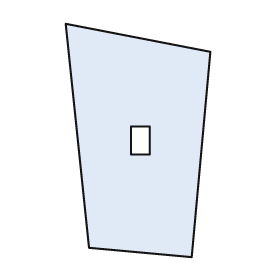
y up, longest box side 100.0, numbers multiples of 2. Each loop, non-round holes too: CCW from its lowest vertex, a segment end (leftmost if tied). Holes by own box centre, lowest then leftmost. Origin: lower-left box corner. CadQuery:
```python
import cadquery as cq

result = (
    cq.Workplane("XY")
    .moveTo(54.0, 0.0)
    .lineTo(62.0, 88.0)
    .lineTo(0.0, 100.0)
    .lineTo(10.0, 4.0)
    .close()
    .moveTo(28.0, 44.0)
    .lineTo(36.0, 44.0)
    .lineTo(36.0, 56.0)
    .lineTo(28.0, 56.0)
    .close()
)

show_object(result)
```